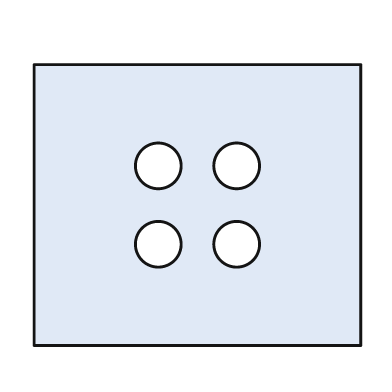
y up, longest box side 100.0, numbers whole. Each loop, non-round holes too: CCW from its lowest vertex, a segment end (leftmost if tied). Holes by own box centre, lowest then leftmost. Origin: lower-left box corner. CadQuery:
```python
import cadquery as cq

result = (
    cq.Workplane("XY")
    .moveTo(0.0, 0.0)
    .lineTo(100.0, 0.0)
    .lineTo(100.0, 86.0)
    .lineTo(0.0, 86.0)
    .close()
    .moveTo(38.0, 31.0)
    .circle(7.0)
    .moveTo(62.0, 31.0)
    .circle(7.0)
    .moveTo(38.0, 55.0)
    .circle(7.0)
    .moveTo(62.0, 55.0)
    .circle(7.0)
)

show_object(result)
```